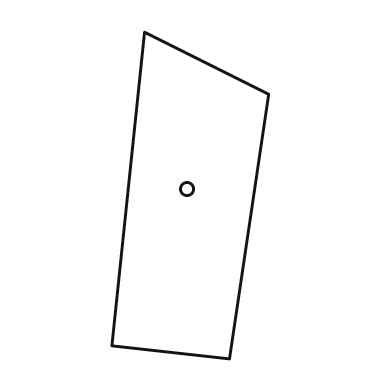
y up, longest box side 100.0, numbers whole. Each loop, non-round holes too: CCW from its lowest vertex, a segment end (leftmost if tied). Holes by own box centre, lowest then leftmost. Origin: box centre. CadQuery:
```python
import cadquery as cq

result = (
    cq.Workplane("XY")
    .moveTo(12.0, -50.0)
    .lineTo(24.0, 31.0)
    .lineTo(-14.0, 50.0)
    .lineTo(-24.0, -46.0)
    .close()
    .moveTo(-1.0, 2.0)
    .circle(2.0)
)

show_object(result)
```